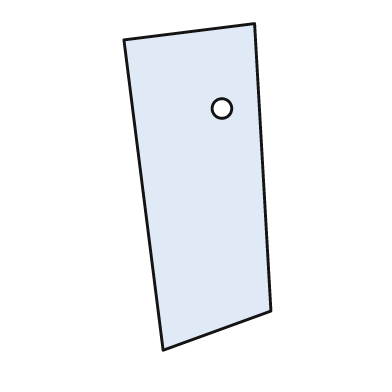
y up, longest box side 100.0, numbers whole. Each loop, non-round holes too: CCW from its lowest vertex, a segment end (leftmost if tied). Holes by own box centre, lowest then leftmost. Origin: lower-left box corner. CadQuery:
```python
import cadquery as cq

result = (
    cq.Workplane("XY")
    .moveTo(12.0, 0.0)
    .lineTo(45.0, 12.0)
    .lineTo(40.0, 100.0)
    .lineTo(0.0, 95.0)
    .close()
    .moveTo(30.0, 74.0)
    .circle(3.0)
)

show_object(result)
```